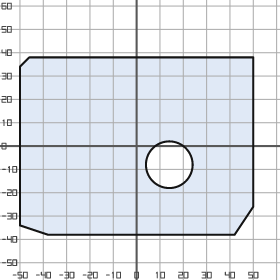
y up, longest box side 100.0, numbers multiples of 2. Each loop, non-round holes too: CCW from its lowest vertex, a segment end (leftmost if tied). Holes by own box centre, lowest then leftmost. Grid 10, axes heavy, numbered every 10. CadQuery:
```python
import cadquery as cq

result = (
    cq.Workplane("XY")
    .moveTo(-38.0, -38.0)
    .lineTo(42.0, -38.0)
    .lineTo(50.0, -26.0)
    .lineTo(50.0, 38.0)
    .lineTo(-46.0, 38.0)
    .lineTo(-50.0, 34.0)
    .lineTo(-50.0, -34.0)
    .close()
    .moveTo(14.0, -8.0)
    .circle(10.0)
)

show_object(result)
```